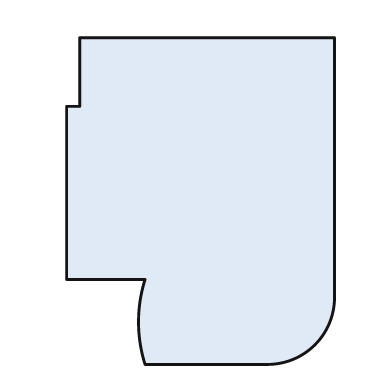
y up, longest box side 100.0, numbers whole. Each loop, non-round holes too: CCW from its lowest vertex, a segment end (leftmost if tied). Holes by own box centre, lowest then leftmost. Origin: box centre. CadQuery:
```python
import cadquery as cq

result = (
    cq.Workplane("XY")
    .moveTo(-17.0, -50.0)
    .lineTo(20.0, -50.0)
    .threePointArc((35.0, -44.0), (41.0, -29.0))
    .lineTo(41.0, 50.0)
    .lineTo(-37.0, 50.0)
    .lineTo(-37.0, 29.0)
    .lineTo(-41.0, 29.0)
    .lineTo(-41.0, -24.0)
    .lineTo(-17.0, -24.0)
    .threePointArc((-19.0, -37.0), (-17.0, -50.0))
    .close()
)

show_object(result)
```